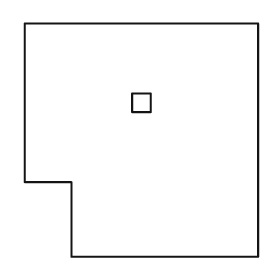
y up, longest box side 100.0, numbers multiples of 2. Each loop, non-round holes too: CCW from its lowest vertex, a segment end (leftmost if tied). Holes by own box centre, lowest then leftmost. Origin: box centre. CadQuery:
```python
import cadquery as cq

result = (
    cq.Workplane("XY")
    .moveTo(-30.0, -50.0)
    .lineTo(50.0, -50.0)
    .lineTo(50.0, 50.0)
    .lineTo(-50.0, 50.0)
    .lineTo(-50.0, -18.0)
    .lineTo(-30.0, -18.0)
    .close()
    .moveTo(-4.0, 12.0)
    .lineTo(4.0, 12.0)
    .lineTo(4.0, 20.0)
    .lineTo(-4.0, 20.0)
    .close()
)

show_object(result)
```